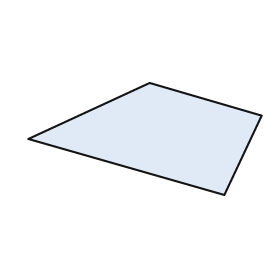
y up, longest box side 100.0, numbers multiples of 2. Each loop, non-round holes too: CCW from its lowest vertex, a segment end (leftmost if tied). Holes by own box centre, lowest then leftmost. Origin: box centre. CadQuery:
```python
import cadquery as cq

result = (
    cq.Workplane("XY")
    .moveTo(34.0, -24.0)
    .lineTo(50.0, 10.0)
    .lineTo(2.0, 24.0)
    .lineTo(-50.0, 0.0)
    .close()
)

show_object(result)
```